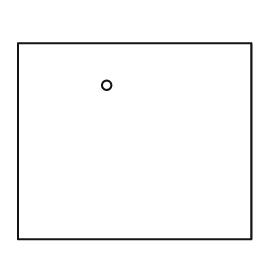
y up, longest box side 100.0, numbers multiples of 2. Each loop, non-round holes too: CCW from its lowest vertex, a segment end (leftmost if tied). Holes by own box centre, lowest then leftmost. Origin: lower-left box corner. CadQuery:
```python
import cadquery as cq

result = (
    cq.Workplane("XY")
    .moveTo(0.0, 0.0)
    .lineTo(100.0, 0.0)
    .lineTo(100.0, 84.0)
    .lineTo(0.0, 84.0)
    .close()
    .moveTo(38.0, 66.0)
    .circle(2.0)
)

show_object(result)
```